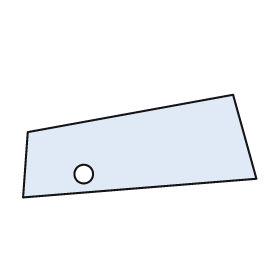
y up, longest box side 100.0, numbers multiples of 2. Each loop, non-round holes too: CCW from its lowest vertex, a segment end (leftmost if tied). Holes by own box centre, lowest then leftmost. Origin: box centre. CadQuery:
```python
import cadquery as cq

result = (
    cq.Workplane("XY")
    .moveTo(-50.0, -22.0)
    .lineTo(50.0, -14.0)
    .lineTo(40.0, 22.0)
    .lineTo(-48.0, 6.0)
    .close()
    .moveTo(-24.0, -12.0)
    .circle(4.0)
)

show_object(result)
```